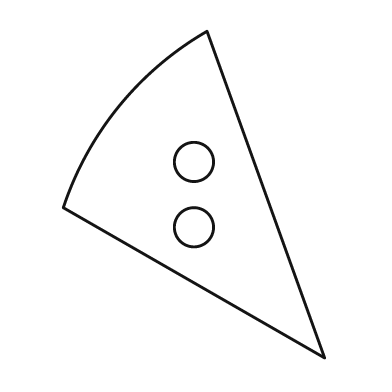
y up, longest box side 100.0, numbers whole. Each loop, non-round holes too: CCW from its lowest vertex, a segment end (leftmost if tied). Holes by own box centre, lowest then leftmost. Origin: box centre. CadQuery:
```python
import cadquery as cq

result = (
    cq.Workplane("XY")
    .moveTo(40.0, -50.0)
    .lineTo(4.0, 50.0)
    .threePointArc((-23.0, 27.0), (-40.0, -4.0))
    .close()
    .moveTo(0.0, -10.0)
    .circle(6.0)
    .moveTo(0.0, 10.0)
    .circle(6.0)
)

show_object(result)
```